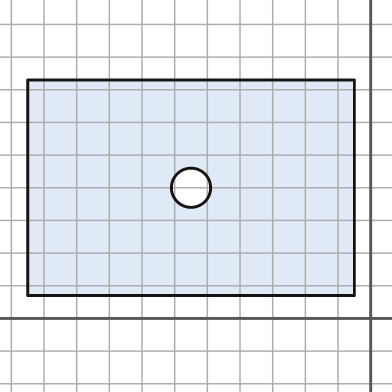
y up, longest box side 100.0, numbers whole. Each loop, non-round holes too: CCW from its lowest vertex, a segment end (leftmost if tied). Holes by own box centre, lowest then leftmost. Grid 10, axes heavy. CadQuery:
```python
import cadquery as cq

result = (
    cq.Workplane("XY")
    .moveTo(-105.0, 7.0)
    .lineTo(-5.0, 7.0)
    .lineTo(-5.0, 73.0)
    .lineTo(-105.0, 73.0)
    .close()
    .moveTo(-55.0, 40.0)
    .circle(6.0)
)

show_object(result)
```